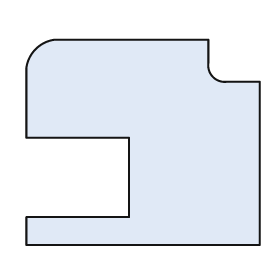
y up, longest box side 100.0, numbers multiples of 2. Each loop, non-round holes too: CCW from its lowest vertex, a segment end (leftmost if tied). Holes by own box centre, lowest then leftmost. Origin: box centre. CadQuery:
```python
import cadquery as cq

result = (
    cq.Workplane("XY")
    .moveTo(-50.0, -44.0)
    .lineTo(50.0, -44.0)
    .lineTo(50.0, 26.0)
    .lineTo(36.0, 26.0)
    .threePointArc((30.0, 28.0), (28.0, 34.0))
    .lineTo(28.0, 44.0)
    .lineTo(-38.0, 44.0)
    .threePointArc((-46.0, 40.0), (-50.0, 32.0))
    .lineTo(-50.0, 2.0)
    .lineTo(-6.0, 2.0)
    .lineTo(-6.0, -32.0)
    .lineTo(-50.0, -32.0)
    .close()
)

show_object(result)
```